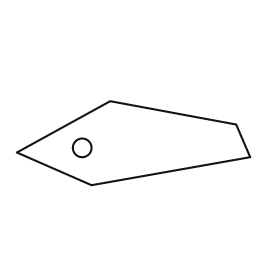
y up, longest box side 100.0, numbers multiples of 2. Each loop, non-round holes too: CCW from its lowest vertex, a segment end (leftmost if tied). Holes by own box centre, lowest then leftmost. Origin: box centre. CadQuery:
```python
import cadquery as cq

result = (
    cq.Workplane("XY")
    .moveTo(-18.0, -18.0)
    .lineTo(50.0, -6.0)
    .lineTo(44.0, 8.0)
    .lineTo(-10.0, 18.0)
    .lineTo(-50.0, -4.0)
    .close()
    .moveTo(-22.0, -2.0)
    .circle(4.0)
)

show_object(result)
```